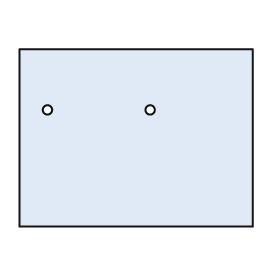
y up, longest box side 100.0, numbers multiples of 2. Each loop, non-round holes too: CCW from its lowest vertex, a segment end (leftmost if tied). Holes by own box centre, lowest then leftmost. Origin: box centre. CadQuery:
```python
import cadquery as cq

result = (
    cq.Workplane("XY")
    .moveTo(-50.0, -38.0)
    .lineTo(50.0, -38.0)
    .lineTo(50.0, 38.0)
    .lineTo(-50.0, 38.0)
    .close()
    .moveTo(-38.0, 12.0)
    .circle(2.0)
    .moveTo(6.0, 12.0)
    .circle(2.0)
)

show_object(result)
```